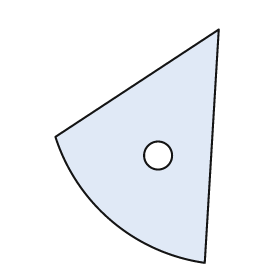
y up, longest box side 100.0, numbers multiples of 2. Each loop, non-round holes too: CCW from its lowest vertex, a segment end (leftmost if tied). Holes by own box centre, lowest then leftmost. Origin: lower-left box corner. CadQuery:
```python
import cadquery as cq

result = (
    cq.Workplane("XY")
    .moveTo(64.0, 0.0)
    .lineTo(70.0, 100.0)
    .lineTo(0.0, 54.0)
    .threePointArc((24.0, 18.0), (64.0, 0.0))
    .close()
    .moveTo(44.0, 46.0)
    .circle(6.0)
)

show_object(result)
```